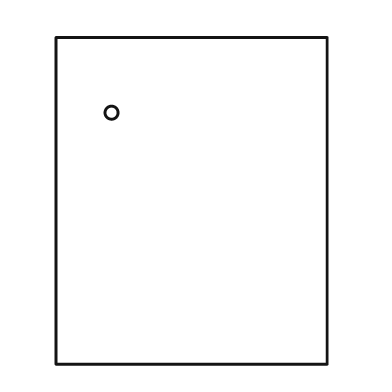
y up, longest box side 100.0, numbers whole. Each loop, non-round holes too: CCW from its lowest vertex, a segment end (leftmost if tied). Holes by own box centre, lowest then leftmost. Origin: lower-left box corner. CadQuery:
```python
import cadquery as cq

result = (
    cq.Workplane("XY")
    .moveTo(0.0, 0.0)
    .lineTo(83.0, 0.0)
    .lineTo(83.0, 100.0)
    .lineTo(0.0, 100.0)
    .close()
    .moveTo(17.0, 77.0)
    .circle(2.0)
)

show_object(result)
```